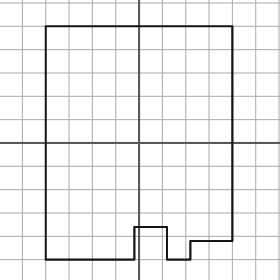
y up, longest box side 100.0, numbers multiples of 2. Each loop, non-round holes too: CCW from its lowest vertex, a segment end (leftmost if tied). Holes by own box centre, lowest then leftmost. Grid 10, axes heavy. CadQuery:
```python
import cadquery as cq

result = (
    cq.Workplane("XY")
    .moveTo(-40.0, -50.0)
    .lineTo(-2.0, -50.0)
    .lineTo(-2.0, -36.0)
    .lineTo(12.0, -36.0)
    .lineTo(12.0, -50.0)
    .lineTo(22.0, -50.0)
    .lineTo(22.0, -42.0)
    .lineTo(40.0, -42.0)
    .lineTo(40.0, 50.0)
    .lineTo(-40.0, 50.0)
    .close()
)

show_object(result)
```